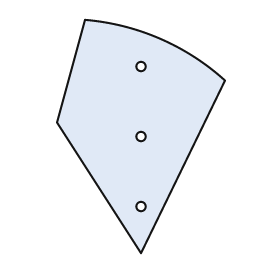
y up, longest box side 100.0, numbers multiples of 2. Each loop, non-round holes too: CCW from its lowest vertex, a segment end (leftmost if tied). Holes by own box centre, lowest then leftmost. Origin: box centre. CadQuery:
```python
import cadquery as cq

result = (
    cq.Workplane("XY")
    .moveTo(0.0, -50.0)
    .lineTo(36.0, 24.0)
    .threePointArc((8.0, 42.0), (-24.0, 50.0))
    .lineTo(-36.0, 6.0)
    .close()
    .moveTo(0.0, -30.0)
    .circle(2.0)
    .moveTo(0.0, 0.0)
    .circle(2.0)
    .moveTo(0.0, 30.0)
    .circle(2.0)
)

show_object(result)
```